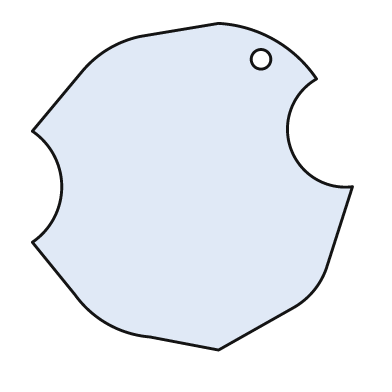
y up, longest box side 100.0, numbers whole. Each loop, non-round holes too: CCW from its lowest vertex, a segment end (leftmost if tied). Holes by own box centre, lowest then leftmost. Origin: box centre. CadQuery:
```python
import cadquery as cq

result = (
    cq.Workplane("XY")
    .moveTo(8.0, -50.0)
    .lineTo(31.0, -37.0)
    .threePointArc((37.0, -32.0), (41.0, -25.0))
    .lineTo(49.0, 0.0)
    .threePointArc((30.0, 12.0), (38.0, 33.0))
    .threePointArc((25.0, 45.0), (8.0, 50.0))
    .lineTo(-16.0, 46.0)
    .threePointArc((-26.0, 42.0), (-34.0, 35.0))
    .lineTo(-49.0, 17.0)
    .threePointArc((-40.0, 0.0), (-49.0, -17.0))
    .lineTo(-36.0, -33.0)
    .threePointArc((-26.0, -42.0), (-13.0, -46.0))
    .close()
    .moveTo(21.0, 39.0)
    .circle(3.0)
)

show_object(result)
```